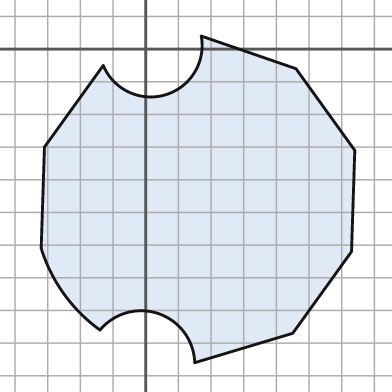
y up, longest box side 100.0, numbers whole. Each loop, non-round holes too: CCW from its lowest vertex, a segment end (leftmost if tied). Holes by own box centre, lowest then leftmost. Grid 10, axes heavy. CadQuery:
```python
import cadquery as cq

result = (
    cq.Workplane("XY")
    .moveTo(15.0, -96.0)
    .lineTo(45.0, -87.0)
    .lineTo(63.0, -62.0)
    .lineTo(64.0, -31.0)
    .lineTo(46.0, -6.0)
    .lineTo(17.0, 4.0)
    .threePointArc((6.0, -14.0), (-13.0, -5.0))
    .lineTo(-31.0, -30.0)
    .lineTo(-32.0, -61.0)
    .threePointArc((-25.0, -75.0), (-14.0, -86.0))
    .threePointArc((4.0, -81.0), (15.0, -96.0))
    .close()
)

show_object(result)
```